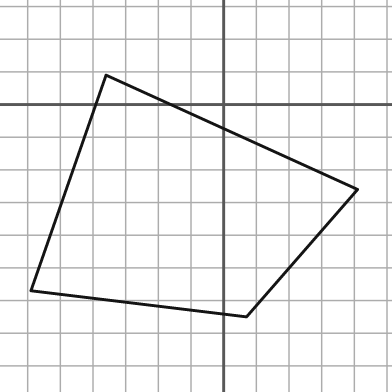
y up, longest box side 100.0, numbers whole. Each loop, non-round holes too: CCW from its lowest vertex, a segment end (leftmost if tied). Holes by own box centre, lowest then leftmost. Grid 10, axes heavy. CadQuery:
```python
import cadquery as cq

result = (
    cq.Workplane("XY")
    .moveTo(7.0, -65.0)
    .lineTo(41.0, -26.0)
    .lineTo(-36.0, 9.0)
    .lineTo(-59.0, -57.0)
    .close()
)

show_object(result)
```